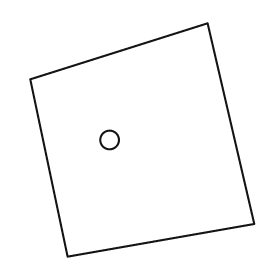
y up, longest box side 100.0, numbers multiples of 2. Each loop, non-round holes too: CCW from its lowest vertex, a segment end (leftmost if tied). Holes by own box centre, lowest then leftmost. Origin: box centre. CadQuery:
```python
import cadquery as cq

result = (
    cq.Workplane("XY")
    .moveTo(-32.0, -50.0)
    .lineTo(48.0, -36.0)
    .lineTo(28.0, 50.0)
    .lineTo(-48.0, 26.0)
    .close()
    .moveTo(-14.0, 0.0)
    .circle(4.0)
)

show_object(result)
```